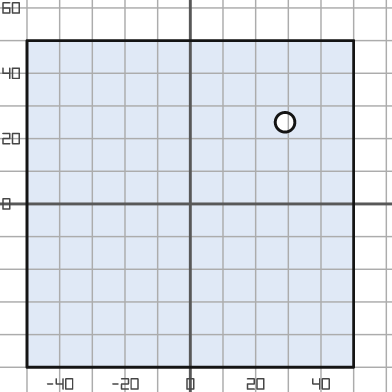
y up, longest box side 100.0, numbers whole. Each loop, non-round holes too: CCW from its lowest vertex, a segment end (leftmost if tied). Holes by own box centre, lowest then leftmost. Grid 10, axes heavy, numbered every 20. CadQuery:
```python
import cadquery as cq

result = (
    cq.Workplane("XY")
    .moveTo(-50.0, -50.0)
    .lineTo(50.0, -50.0)
    .lineTo(50.0, 50.0)
    .lineTo(-50.0, 50.0)
    .close()
    .moveTo(29.0, 25.0)
    .circle(3.0)
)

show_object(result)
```